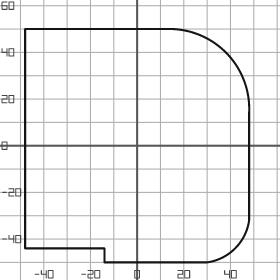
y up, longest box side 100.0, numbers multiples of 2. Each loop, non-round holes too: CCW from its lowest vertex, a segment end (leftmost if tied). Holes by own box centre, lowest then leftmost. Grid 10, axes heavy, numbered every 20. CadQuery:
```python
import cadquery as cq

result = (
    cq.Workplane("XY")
    .moveTo(-14.0, -50.0)
    .lineTo(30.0, -50.0)
    .threePointArc((42.0, -44.0), (48.0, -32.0))
    .lineTo(48.0, 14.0)
    .threePointArc((38.0, 40.0), (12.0, 50.0))
    .lineTo(-48.0, 50.0)
    .lineTo(-48.0, -44.0)
    .lineTo(-14.0, -44.0)
    .close()
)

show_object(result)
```